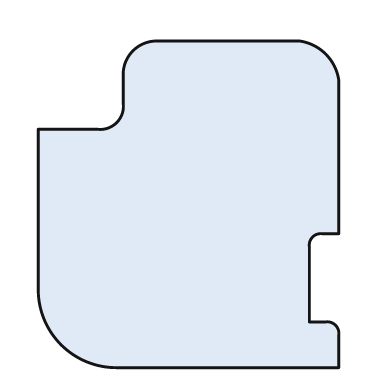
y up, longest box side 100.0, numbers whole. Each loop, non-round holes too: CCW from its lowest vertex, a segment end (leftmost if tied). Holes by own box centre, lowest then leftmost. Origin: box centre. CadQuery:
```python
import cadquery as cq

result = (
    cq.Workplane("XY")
    .moveTo(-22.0, -50.0)
    .lineTo(46.0, -50.0)
    .lineTo(46.0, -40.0)
    .threePointArc((45.0, -37.0), (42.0, -36.0))
    .lineTo(37.0, -36.0)
    .lineTo(37.0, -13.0)
    .threePointArc((38.0, -10.0), (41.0, -9.0))
    .lineTo(46.0, -9.0)
    .lineTo(46.0, 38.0)
    .threePointArc((42.0, 46.0), (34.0, 50.0))
    .lineTo(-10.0, 50.0)
    .threePointArc((-17.0, 47.0), (-20.0, 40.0))
    .lineTo(-20.0, 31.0)
    .threePointArc((-22.0, 25.0), (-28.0, 23.0))
    .lineTo(-46.0, 23.0)
    .lineTo(-46.0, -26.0)
    .threePointArc((-39.0, -43.0), (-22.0, -50.0))
    .close()
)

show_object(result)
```